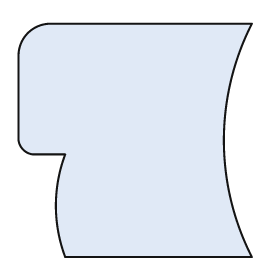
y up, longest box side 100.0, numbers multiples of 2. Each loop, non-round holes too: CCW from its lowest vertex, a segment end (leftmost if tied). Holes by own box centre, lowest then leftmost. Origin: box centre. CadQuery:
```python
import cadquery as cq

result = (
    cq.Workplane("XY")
    .moveTo(-30.0, -50.0)
    .lineTo(50.0, -50.0)
    .threePointArc((38.0, 0.0), (50.0, 50.0))
    .lineTo(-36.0, 50.0)
    .threePointArc((-46.0, 46.0), (-50.0, 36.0))
    .lineTo(-50.0, 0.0)
    .threePointArc((-48.0, -4.0), (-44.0, -6.0))
    .lineTo(-30.0, -6.0)
    .threePointArc((-34.0, -28.0), (-30.0, -50.0))
    .close()
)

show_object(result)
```